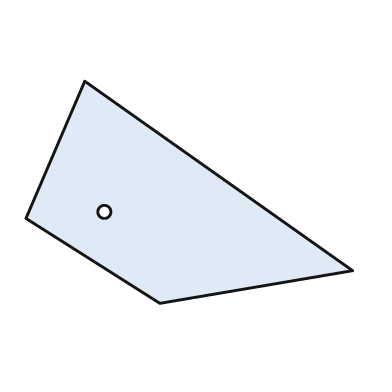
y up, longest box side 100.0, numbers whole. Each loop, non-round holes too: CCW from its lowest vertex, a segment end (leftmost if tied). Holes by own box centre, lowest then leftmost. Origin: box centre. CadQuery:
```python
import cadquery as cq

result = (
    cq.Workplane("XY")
    .moveTo(-9.0, -34.0)
    .lineTo(50.0, -24.0)
    .lineTo(-32.0, 34.0)
    .lineTo(-50.0, -8.0)
    .close()
    .moveTo(-26.0, -6.0)
    .circle(2.0)
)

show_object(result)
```